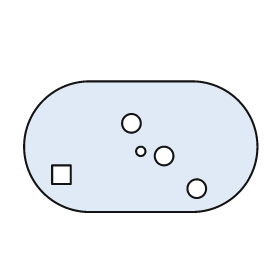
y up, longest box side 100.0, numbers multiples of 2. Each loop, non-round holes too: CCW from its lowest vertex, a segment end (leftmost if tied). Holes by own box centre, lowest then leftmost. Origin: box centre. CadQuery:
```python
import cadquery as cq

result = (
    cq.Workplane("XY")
    .moveTo(-22.0, -28.0)
    .lineTo(22.0, -28.0)
    .threePointArc((50.0, 0.0), (22.0, 28.0))
    .lineTo(-22.0, 28.0)
    .threePointArc((-50.0, 0.0), (-22.0, -28.0))
    .close()
    .moveTo(24.0, -18.0)
    .circle(4.0)
    .moveTo(-38.0, -16.0)
    .lineTo(-30.0, -16.0)
    .lineTo(-30.0, -8.0)
    .lineTo(-38.0, -8.0)
    .close()
    .moveTo(10.0, -4.0)
    .circle(4.0)
    .moveTo(0.0, -2.0)
    .circle(2.0)
    .moveTo(-4.0, 10.0)
    .circle(4.0)
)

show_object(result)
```